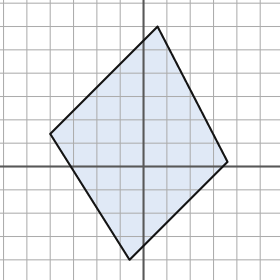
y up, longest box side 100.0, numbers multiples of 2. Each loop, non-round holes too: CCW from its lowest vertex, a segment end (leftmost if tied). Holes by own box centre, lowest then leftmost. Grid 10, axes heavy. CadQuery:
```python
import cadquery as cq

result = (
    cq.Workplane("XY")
    .moveTo(-6.0, -40.0)
    .lineTo(36.0, 2.0)
    .lineTo(6.0, 60.0)
    .lineTo(-40.0, 14.0)
    .close()
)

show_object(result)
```